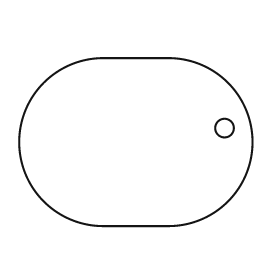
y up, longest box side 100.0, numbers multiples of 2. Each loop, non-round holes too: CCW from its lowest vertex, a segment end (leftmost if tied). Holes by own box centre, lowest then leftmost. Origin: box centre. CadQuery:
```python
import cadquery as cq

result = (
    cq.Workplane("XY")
    .moveTo(-14.0, -36.0)
    .lineTo(14.0, -36.0)
    .threePointArc((50.0, 0.0), (14.0, 36.0))
    .lineTo(-14.0, 36.0)
    .threePointArc((-50.0, 0.0), (-14.0, -36.0))
    .close()
    .moveTo(38.0, 6.0)
    .circle(4.0)
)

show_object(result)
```